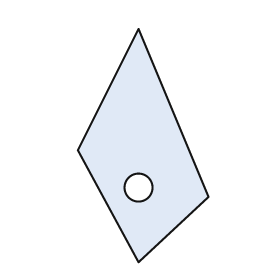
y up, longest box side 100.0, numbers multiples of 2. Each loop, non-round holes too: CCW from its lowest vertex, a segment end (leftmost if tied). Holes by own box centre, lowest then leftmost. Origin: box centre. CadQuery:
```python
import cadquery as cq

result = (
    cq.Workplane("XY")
    .moveTo(-2.0, -50.0)
    .lineTo(28.0, -22.0)
    .lineTo(-2.0, 50.0)
    .lineTo(-28.0, -2.0)
    .close()
    .moveTo(-2.0, -18.0)
    .circle(6.0)
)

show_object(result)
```